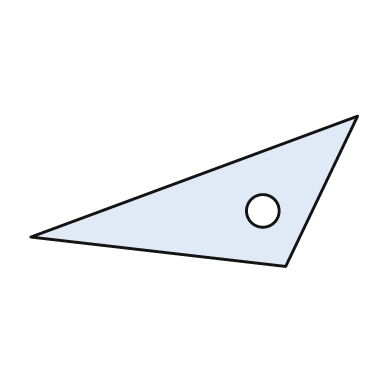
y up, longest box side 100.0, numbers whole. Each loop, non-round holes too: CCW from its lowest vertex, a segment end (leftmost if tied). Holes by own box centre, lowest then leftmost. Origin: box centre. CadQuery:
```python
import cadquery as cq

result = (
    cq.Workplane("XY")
    .moveTo(28.0, -23.0)
    .lineTo(50.0, 23.0)
    .lineTo(-50.0, -14.0)
    .close()
    .moveTo(21.0, -6.0)
    .circle(5.0)
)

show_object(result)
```